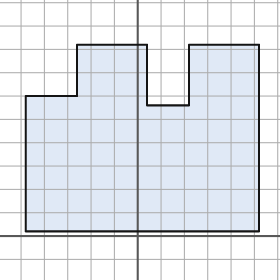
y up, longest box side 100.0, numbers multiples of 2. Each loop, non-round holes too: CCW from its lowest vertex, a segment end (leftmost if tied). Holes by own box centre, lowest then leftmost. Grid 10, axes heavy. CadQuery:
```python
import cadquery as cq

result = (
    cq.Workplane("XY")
    .moveTo(-48.0, 2.0)
    .lineTo(52.0, 2.0)
    .lineTo(52.0, 82.0)
    .lineTo(22.0, 82.0)
    .lineTo(22.0, 56.0)
    .lineTo(4.0, 56.0)
    .lineTo(4.0, 82.0)
    .lineTo(-26.0, 82.0)
    .lineTo(-26.0, 60.0)
    .lineTo(-48.0, 60.0)
    .close()
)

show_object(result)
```